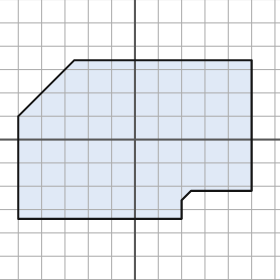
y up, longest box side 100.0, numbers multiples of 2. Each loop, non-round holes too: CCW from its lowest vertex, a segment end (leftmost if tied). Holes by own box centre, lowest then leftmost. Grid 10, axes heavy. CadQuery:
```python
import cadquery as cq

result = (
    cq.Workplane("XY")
    .moveTo(-50.0, -34.0)
    .lineTo(20.0, -34.0)
    .lineTo(20.0, -26.0)
    .lineTo(24.0, -22.0)
    .lineTo(50.0, -22.0)
    .lineTo(50.0, 34.0)
    .lineTo(-26.0, 34.0)
    .lineTo(-50.0, 10.0)
    .close()
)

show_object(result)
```